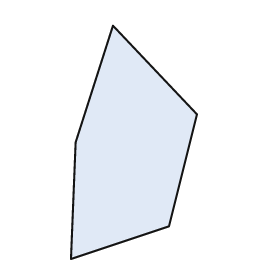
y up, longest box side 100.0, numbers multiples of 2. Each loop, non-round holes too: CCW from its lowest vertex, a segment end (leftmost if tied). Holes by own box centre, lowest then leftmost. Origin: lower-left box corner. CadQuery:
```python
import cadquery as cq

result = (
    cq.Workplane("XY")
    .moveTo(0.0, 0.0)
    .lineTo(42.0, 14.0)
    .lineTo(54.0, 62.0)
    .lineTo(18.0, 100.0)
    .lineTo(2.0, 50.0)
    .close()
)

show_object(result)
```